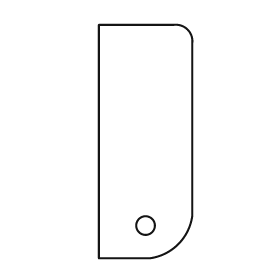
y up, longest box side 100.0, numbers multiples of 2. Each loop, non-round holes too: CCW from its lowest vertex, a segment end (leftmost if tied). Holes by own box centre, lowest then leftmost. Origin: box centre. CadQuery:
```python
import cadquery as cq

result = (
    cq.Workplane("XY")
    .moveTo(-20.0, -50.0)
    .lineTo(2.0, -50.0)
    .threePointArc((14.0, -44.0), (20.0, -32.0))
    .lineTo(20.0, 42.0)
    .threePointArc((18.0, 48.0), (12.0, 50.0))
    .lineTo(-20.0, 50.0)
    .close()
    .moveTo(0.0, -36.0)
    .circle(4.0)
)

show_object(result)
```